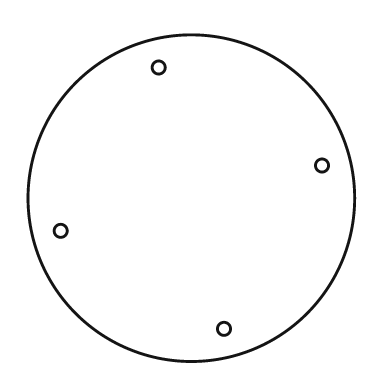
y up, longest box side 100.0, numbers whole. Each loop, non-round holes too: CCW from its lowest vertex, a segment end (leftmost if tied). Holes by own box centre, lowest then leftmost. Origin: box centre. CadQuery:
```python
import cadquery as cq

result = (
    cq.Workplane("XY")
    .moveTo(0.0, 0.0)
    .circle(50.0)
    .moveTo(10.0, -40.0)
    .circle(2.0)
    .moveTo(-40.0, -10.0)
    .circle(2.0)
    .moveTo(40.0, 10.0)
    .circle(2.0)
    .moveTo(-10.0, 40.0)
    .circle(2.0)
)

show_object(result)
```